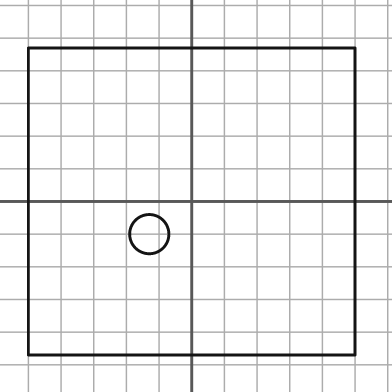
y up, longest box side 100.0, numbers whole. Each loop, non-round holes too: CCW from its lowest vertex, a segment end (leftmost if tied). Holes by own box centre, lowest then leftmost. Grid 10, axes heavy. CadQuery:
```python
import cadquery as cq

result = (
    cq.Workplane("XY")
    .moveTo(-50.0, -47.0)
    .lineTo(50.0, -47.0)
    .lineTo(50.0, 47.0)
    .lineTo(-50.0, 47.0)
    .close()
    .moveTo(-13.0, -10.0)
    .circle(6.0)
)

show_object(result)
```